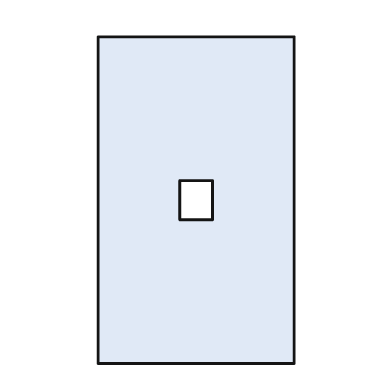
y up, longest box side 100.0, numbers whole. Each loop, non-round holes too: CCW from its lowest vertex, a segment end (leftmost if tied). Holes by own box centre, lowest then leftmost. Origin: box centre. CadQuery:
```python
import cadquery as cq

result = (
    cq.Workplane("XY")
    .moveTo(-30.0, -50.0)
    .lineTo(30.0, -50.0)
    .lineTo(30.0, 50.0)
    .lineTo(-30.0, 50.0)
    .close()
    .moveTo(-5.0, -6.0)
    .lineTo(5.0, -6.0)
    .lineTo(5.0, 6.0)
    .lineTo(-5.0, 6.0)
    .close()
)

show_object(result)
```